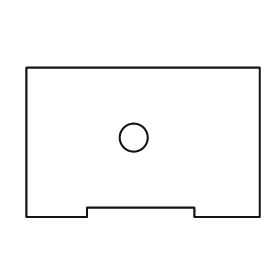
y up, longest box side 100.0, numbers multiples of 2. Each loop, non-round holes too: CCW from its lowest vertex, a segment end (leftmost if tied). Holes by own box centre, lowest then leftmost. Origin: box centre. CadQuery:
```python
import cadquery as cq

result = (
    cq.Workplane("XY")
    .moveTo(-50.0, -32.0)
    .lineTo(-24.0, -32.0)
    .lineTo(-24.0, -28.0)
    .lineTo(22.0, -28.0)
    .lineTo(22.0, -32.0)
    .lineTo(50.0, -32.0)
    .lineTo(50.0, 32.0)
    .lineTo(-50.0, 32.0)
    .close()
    .moveTo(-4.0, 2.0)
    .circle(6.0)
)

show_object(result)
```